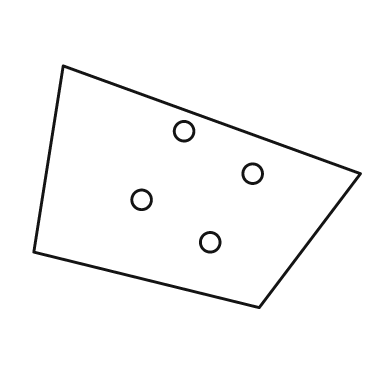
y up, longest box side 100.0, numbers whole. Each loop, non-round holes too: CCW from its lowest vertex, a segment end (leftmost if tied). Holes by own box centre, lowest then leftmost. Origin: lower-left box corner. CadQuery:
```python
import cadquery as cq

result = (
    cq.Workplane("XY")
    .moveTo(69.0, 0.0)
    .lineTo(100.0, 41.0)
    .lineTo(9.0, 74.0)
    .lineTo(0.0, 17.0)
    .close()
    .moveTo(54.0, 20.0)
    .circle(3.0)
    .moveTo(33.0, 33.0)
    .circle(3.0)
    .moveTo(67.0, 41.0)
    .circle(3.0)
    .moveTo(46.0, 54.0)
    .circle(3.0)
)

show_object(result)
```